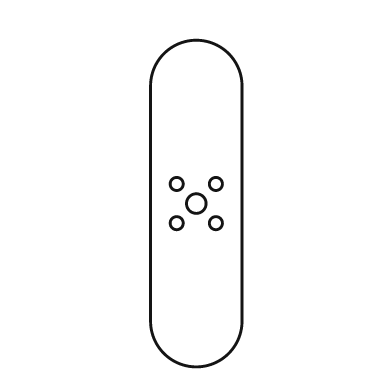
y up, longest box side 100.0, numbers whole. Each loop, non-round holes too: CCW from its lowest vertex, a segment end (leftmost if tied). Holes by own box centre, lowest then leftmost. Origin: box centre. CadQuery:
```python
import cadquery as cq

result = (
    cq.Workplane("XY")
    .moveTo(-14.0, -36.0)
    .threePointArc((0.0, -50.0), (14.0, -36.0))
    .lineTo(14.0, 36.0)
    .threePointArc((0.0, 50.0), (-14.0, 36.0))
    .close()
    .moveTo(-6.0, -6.0)
    .circle(2.0)
    .moveTo(6.0, -6.0)
    .circle(2.0)
    .moveTo(0.0, 0.0)
    .circle(3.0)
    .moveTo(-6.0, 6.0)
    .circle(2.0)
    .moveTo(6.0, 6.0)
    .circle(2.0)
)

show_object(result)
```